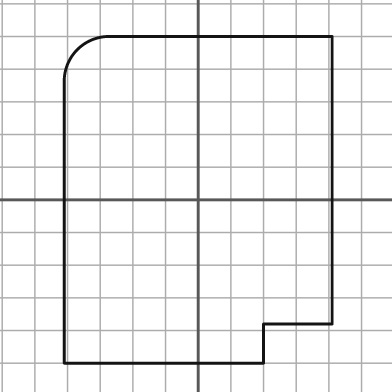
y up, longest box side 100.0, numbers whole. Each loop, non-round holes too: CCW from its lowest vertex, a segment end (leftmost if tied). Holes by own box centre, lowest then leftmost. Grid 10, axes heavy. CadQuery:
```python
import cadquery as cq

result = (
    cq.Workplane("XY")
    .moveTo(-41.0, -50.0)
    .lineTo(20.0, -50.0)
    .lineTo(20.0, -38.0)
    .lineTo(41.0, -38.0)
    .lineTo(41.0, 50.0)
    .lineTo(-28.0, 50.0)
    .threePointArc((-37.0, 46.0), (-41.0, 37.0))
    .close()
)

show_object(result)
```